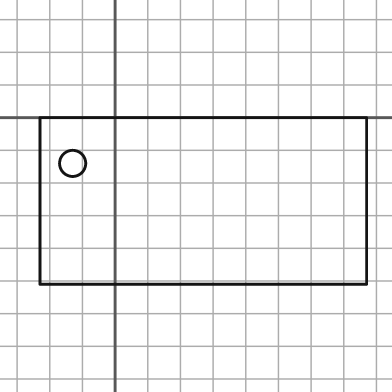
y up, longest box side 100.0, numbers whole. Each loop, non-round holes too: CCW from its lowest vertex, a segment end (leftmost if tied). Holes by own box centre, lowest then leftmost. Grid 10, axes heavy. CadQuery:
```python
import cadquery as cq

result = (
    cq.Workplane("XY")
    .moveTo(-23.0, -51.0)
    .lineTo(77.0, -51.0)
    .lineTo(77.0, 0.0)
    .lineTo(-23.0, 0.0)
    .close()
    .moveTo(-13.0, -14.0)
    .circle(4.0)
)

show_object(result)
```